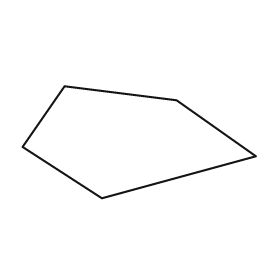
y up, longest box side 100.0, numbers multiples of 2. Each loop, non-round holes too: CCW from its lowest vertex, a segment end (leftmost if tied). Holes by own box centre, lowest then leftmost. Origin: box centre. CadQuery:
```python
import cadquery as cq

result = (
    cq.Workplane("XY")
    .moveTo(-16.0, -24.0)
    .lineTo(50.0, -6.0)
    .lineTo(16.0, 18.0)
    .lineTo(-32.0, 24.0)
    .lineTo(-50.0, -2.0)
    .close()
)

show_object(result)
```